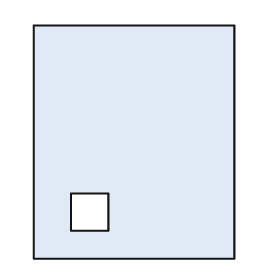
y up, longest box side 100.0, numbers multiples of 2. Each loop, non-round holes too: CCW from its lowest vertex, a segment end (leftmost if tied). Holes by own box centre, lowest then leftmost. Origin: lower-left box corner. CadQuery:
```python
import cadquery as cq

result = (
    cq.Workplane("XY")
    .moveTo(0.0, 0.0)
    .lineTo(86.0, 0.0)
    .lineTo(86.0, 100.0)
    .lineTo(0.0, 100.0)
    .close()
    .moveTo(16.0, 12.0)
    .lineTo(32.0, 12.0)
    .lineTo(32.0, 28.0)
    .lineTo(16.0, 28.0)
    .close()
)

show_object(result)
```